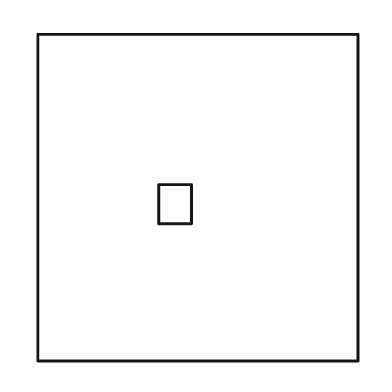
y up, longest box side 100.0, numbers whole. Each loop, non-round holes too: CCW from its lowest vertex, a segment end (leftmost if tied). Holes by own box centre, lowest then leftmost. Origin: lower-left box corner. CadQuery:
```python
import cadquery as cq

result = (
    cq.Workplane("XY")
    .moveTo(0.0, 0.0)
    .lineTo(98.0, 0.0)
    .lineTo(98.0, 100.0)
    .lineTo(0.0, 100.0)
    .close()
    .moveTo(37.0, 42.0)
    .lineTo(47.0, 42.0)
    .lineTo(47.0, 54.0)
    .lineTo(37.0, 54.0)
    .close()
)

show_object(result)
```